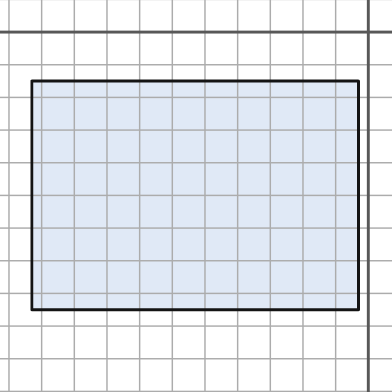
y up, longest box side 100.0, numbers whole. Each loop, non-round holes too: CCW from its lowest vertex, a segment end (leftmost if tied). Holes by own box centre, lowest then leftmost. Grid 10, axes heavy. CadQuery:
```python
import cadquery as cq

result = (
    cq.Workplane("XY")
    .moveTo(-103.0, -85.0)
    .lineTo(-3.0, -85.0)
    .lineTo(-3.0, -15.0)
    .lineTo(-103.0, -15.0)
    .close()
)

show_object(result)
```